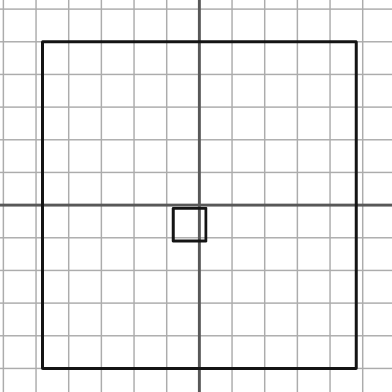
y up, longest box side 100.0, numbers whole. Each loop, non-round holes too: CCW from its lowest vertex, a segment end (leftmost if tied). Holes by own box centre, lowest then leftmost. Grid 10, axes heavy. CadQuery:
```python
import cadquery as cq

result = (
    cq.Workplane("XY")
    .moveTo(-48.0, -50.0)
    .lineTo(48.0, -50.0)
    .lineTo(48.0, 50.0)
    .lineTo(-48.0, 50.0)
    .close()
    .moveTo(-8.0, -11.0)
    .lineTo(2.0, -11.0)
    .lineTo(2.0, -1.0)
    .lineTo(-8.0, -1.0)
    .close()
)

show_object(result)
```